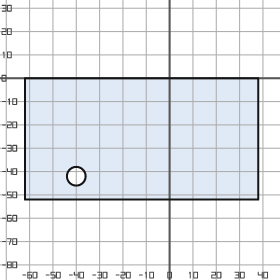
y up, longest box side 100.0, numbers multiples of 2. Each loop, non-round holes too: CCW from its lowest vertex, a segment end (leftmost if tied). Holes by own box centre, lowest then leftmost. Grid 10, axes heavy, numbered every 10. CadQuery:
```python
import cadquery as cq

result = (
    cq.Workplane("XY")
    .moveTo(-62.0, -52.0)
    .lineTo(38.0, -52.0)
    .lineTo(38.0, 0.0)
    .lineTo(-62.0, 0.0)
    .close()
    .moveTo(-40.0, -42.0)
    .circle(4.0)
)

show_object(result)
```